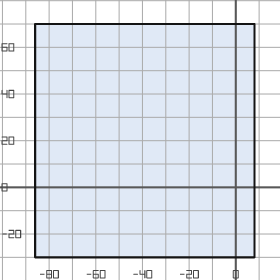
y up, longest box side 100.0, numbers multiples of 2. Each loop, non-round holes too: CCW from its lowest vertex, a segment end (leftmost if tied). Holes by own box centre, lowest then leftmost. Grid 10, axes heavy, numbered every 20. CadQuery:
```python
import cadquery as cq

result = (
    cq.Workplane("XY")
    .moveTo(-86.0, -30.0)
    .lineTo(8.0, -30.0)
    .lineTo(8.0, 70.0)
    .lineTo(-86.0, 70.0)
    .close()
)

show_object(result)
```